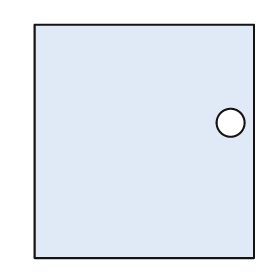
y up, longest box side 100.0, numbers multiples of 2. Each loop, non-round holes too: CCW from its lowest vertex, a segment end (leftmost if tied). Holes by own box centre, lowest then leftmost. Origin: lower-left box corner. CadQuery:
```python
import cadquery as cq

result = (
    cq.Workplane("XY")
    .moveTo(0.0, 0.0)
    .lineTo(94.0, 0.0)
    .lineTo(94.0, 100.0)
    .lineTo(0.0, 100.0)
    .close()
    .moveTo(84.0, 58.0)
    .circle(6.0)
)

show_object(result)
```